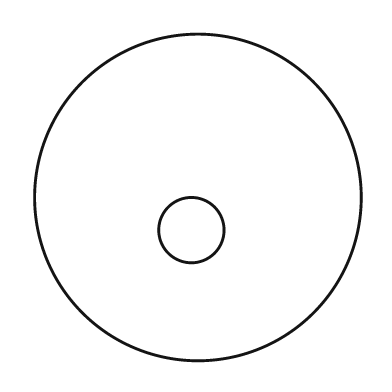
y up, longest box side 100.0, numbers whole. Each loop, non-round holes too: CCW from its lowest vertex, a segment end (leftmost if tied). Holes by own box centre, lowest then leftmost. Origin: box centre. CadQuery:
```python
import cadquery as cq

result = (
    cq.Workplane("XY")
    .moveTo(0.0, 0.0)
    .circle(50.0)
    .moveTo(-2.0, -10.0)
    .circle(10.0)
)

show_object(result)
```